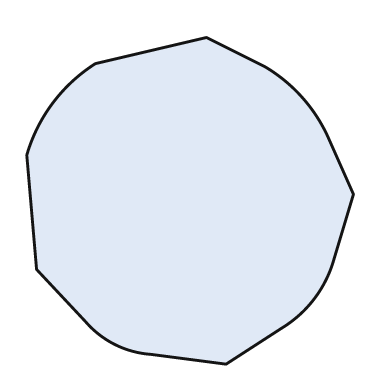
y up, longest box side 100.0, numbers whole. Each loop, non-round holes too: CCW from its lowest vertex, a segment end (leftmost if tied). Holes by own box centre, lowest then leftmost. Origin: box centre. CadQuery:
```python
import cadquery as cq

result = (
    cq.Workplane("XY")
    .moveTo(11.0, -50.0)
    .lineTo(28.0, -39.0)
    .threePointArc((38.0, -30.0), (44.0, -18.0))
    .lineTo(50.0, 2.0)
    .lineTo(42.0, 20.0)
    .threePointArc((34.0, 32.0), (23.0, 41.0))
    .lineTo(5.0, 50.0)
    .lineTo(-29.0, 42.0)
    .threePointArc((-42.0, 30.0), (-50.0, 14.0))
    .lineTo(-47.0, -21.0)
    .lineTo(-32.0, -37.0)
    .threePointArc((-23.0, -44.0), (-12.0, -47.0))
    .close()
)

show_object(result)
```